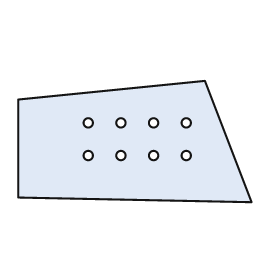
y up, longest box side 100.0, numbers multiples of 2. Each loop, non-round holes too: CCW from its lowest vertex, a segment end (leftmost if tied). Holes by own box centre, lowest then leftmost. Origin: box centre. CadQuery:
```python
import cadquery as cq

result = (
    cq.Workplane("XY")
    .moveTo(50.0, -26.0)
    .lineTo(30.0, 26.0)
    .lineTo(-50.0, 18.0)
    .lineTo(-50.0, -24.0)
    .close()
    .moveTo(-20.0, -6.0)
    .circle(2.0)
    .moveTo(-6.0, -6.0)
    .circle(2.0)
    .moveTo(8.0, -6.0)
    .circle(2.0)
    .moveTo(22.0, -6.0)
    .circle(2.0)
    .moveTo(-20.0, 8.0)
    .circle(2.0)
    .moveTo(-6.0, 8.0)
    .circle(2.0)
    .moveTo(8.0, 8.0)
    .circle(2.0)
    .moveTo(22.0, 8.0)
    .circle(2.0)
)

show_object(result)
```